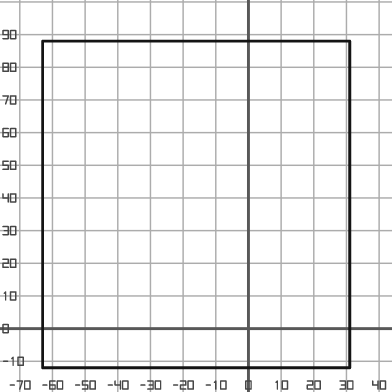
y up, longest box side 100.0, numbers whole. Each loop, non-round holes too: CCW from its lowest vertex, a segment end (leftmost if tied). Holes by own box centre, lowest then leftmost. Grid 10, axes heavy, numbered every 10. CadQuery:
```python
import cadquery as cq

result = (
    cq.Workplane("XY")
    .moveTo(-63.0, -12.0)
    .lineTo(31.0, -12.0)
    .lineTo(31.0, 88.0)
    .lineTo(-63.0, 88.0)
    .close()
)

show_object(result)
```